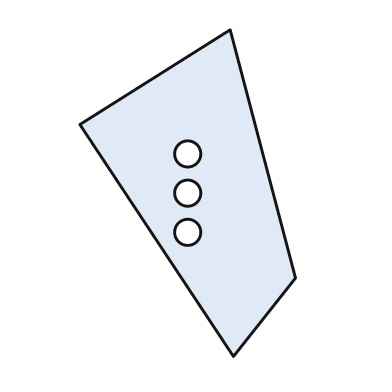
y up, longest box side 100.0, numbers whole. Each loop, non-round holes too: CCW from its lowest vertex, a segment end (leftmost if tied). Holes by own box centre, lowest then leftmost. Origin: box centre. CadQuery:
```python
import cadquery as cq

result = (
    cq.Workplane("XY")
    .moveTo(14.0, -50.0)
    .lineTo(33.0, -26.0)
    .lineTo(13.0, 50.0)
    .lineTo(-33.0, 21.0)
    .close()
    .moveTo(0.0, -12.0)
    .circle(4.0)
    .moveTo(0.0, 0.0)
    .circle(4.0)
    .moveTo(0.0, 12.0)
    .circle(4.0)
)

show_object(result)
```